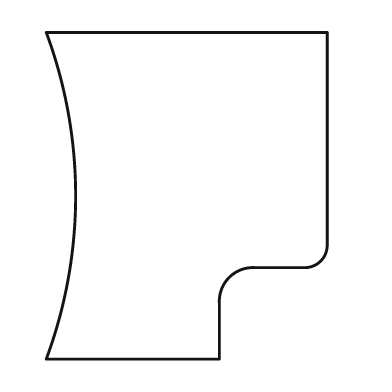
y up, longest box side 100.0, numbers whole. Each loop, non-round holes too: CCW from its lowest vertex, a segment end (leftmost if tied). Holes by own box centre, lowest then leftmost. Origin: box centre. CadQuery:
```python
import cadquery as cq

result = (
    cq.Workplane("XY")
    .moveTo(-43.0, -50.0)
    .lineTo(10.0, -50.0)
    .lineTo(10.0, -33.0)
    .threePointArc((13.0, -25.0), (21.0, -22.0))
    .lineTo(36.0, -22.0)
    .threePointArc((41.0, -20.0), (43.0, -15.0))
    .lineTo(43.0, 50.0)
    .lineTo(-43.0, 50.0)
    .threePointArc((-34.0, 0.0), (-43.0, -50.0))
    .close()
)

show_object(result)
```